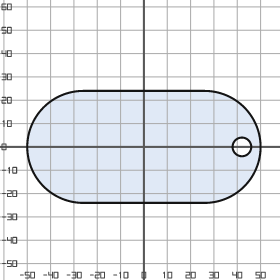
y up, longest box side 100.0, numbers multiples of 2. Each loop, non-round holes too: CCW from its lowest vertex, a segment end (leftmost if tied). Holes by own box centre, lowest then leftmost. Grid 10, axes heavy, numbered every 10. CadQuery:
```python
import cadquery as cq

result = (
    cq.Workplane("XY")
    .moveTo(-26.0, -24.0)
    .lineTo(26.0, -24.0)
    .threePointArc((50.0, 0.0), (26.0, 24.0))
    .lineTo(-26.0, 24.0)
    .threePointArc((-50.0, 0.0), (-26.0, -24.0))
    .close()
    .moveTo(42.0, 0.0)
    .circle(4.0)
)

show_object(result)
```